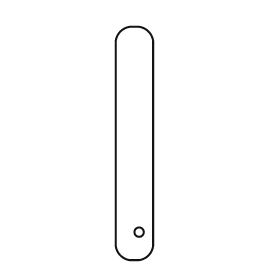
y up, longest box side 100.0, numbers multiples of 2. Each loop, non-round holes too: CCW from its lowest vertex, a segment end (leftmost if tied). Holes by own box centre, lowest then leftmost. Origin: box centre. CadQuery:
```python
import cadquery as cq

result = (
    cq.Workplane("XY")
    .moveTo(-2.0, -50.0)
    .lineTo(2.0, -50.0)
    .threePointArc((6.0, -48.0), (8.0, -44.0))
    .lineTo(8.0, 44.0)
    .threePointArc((6.0, 48.0), (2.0, 50.0))
    .lineTo(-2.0, 50.0)
    .threePointArc((-6.0, 48.0), (-8.0, 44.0))
    .lineTo(-8.0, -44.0)
    .threePointArc((-6.0, -48.0), (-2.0, -50.0))
    .close()
    .moveTo(2.0, -38.0)
    .circle(2.0)
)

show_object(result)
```